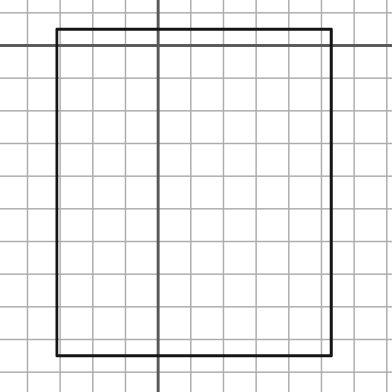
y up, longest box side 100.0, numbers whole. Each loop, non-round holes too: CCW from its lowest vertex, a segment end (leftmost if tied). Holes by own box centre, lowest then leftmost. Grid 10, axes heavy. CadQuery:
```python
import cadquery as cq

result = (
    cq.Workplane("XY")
    .moveTo(-31.0, -95.0)
    .lineTo(53.0, -95.0)
    .lineTo(53.0, 5.0)
    .lineTo(-31.0, 5.0)
    .close()
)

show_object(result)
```